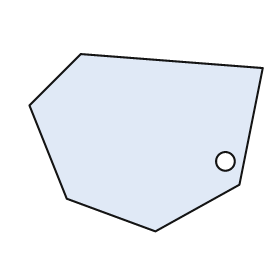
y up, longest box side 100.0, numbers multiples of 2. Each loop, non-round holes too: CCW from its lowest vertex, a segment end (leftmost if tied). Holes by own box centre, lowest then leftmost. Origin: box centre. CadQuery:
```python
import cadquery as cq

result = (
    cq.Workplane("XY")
    .moveTo(4.0, -38.0)
    .lineTo(40.0, -18.0)
    .lineTo(50.0, 32.0)
    .lineTo(-28.0, 38.0)
    .lineTo(-50.0, 16.0)
    .lineTo(-34.0, -24.0)
    .close()
    .moveTo(34.0, -8.0)
    .circle(4.0)
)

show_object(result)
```